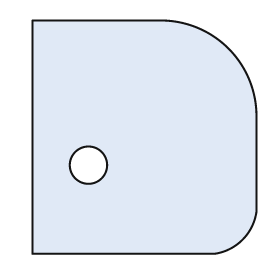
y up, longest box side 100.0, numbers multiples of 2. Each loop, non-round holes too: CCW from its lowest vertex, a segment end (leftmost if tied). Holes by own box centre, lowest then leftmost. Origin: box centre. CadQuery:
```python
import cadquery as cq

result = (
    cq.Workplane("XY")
    .moveTo(-48.0, -50.0)
    .lineTo(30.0, -50.0)
    .threePointArc((42.0, -44.0), (48.0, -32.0))
    .lineTo(48.0, 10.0)
    .threePointArc((36.0, 38.0), (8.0, 50.0))
    .lineTo(-48.0, 50.0)
    .close()
    .moveTo(-24.0, -12.0)
    .circle(8.0)
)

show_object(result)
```